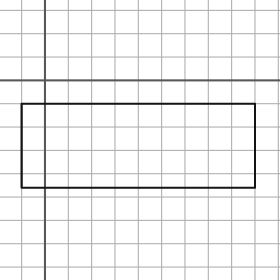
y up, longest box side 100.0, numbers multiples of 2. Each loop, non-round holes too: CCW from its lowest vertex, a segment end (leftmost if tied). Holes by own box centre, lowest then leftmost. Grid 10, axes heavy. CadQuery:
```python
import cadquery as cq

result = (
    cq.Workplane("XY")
    .moveTo(-10.0, -46.0)
    .lineTo(90.0, -46.0)
    .lineTo(90.0, -10.0)
    .lineTo(-10.0, -10.0)
    .close()
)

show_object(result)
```